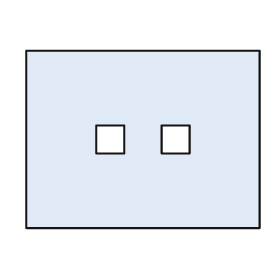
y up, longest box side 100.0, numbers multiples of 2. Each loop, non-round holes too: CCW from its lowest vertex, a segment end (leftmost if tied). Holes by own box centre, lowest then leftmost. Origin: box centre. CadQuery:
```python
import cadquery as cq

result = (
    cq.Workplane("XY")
    .moveTo(-50.0, -38.0)
    .lineTo(50.0, -38.0)
    .lineTo(50.0, 38.0)
    .lineTo(-50.0, 38.0)
    .close()
    .moveTo(-20.0, -6.0)
    .lineTo(-8.0, -6.0)
    .lineTo(-8.0, 6.0)
    .lineTo(-20.0, 6.0)
    .close()
    .moveTo(8.0, -6.0)
    .lineTo(20.0, -6.0)
    .lineTo(20.0, 6.0)
    .lineTo(8.0, 6.0)
    .close()
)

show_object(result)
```